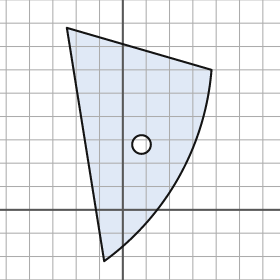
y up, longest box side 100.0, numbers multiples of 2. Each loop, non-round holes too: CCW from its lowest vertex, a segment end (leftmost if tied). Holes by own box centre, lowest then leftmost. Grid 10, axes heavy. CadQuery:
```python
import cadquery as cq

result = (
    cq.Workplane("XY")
    .moveTo(-8.0, -22.0)
    .threePointArc((24.0, 14.0), (38.0, 60.0))
    .lineTo(-24.0, 78.0)
    .close()
    .moveTo(8.0, 28.0)
    .circle(4.0)
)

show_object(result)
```